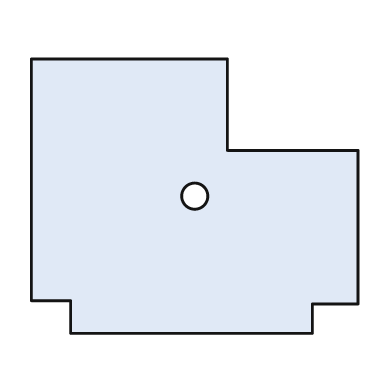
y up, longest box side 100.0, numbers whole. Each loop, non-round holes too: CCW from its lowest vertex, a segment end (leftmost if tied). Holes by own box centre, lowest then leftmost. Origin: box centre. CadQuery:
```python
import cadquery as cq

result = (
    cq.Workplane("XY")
    .moveTo(-38.0, -42.0)
    .lineTo(36.0, -42.0)
    .lineTo(36.0, -33.0)
    .lineTo(50.0, -33.0)
    .lineTo(50.0, 14.0)
    .lineTo(10.0, 14.0)
    .lineTo(10.0, 42.0)
    .lineTo(-50.0, 42.0)
    .lineTo(-50.0, -32.0)
    .lineTo(-38.0, -32.0)
    .close()
    .moveTo(0.0, 0.0)
    .circle(4.0)
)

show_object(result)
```